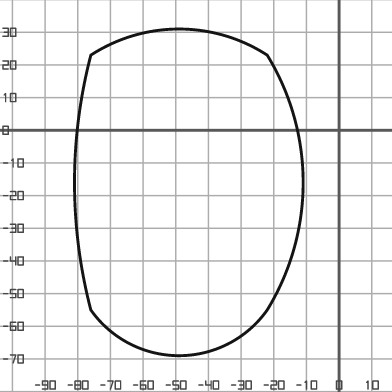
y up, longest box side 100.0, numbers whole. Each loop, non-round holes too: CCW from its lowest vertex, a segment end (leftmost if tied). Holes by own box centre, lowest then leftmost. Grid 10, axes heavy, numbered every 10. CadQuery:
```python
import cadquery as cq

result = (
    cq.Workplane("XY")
    .moveTo(-76.0, -55.0)
    .threePointArc((-49.0, -69.0), (-22.0, -55.0))
    .threePointArc((-11.0, -16.0), (-22.0, 23.0))
    .threePointArc((-49.0, 31.0), (-76.0, 23.0))
    .threePointArc((-81.0, -16.0), (-76.0, -55.0))
    .close()
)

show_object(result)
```